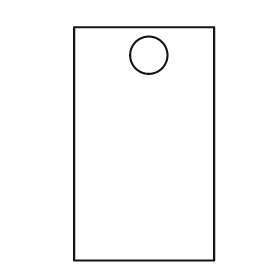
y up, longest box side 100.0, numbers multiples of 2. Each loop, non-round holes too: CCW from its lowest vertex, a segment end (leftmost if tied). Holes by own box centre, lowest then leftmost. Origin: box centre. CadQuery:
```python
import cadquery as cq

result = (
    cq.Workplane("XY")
    .moveTo(-30.0, -50.0)
    .lineTo(30.0, -50.0)
    .lineTo(30.0, 50.0)
    .lineTo(-30.0, 50.0)
    .close()
    .moveTo(2.0, 38.0)
    .circle(8.0)
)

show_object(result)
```